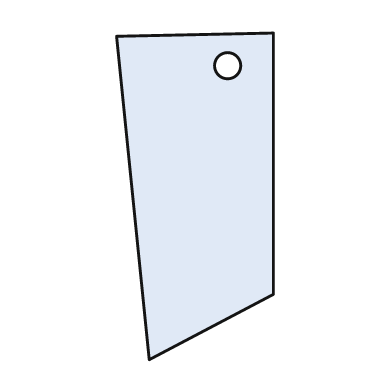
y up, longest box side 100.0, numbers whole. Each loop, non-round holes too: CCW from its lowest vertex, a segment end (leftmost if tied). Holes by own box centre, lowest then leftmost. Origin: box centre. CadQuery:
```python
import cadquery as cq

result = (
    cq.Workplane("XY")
    .moveTo(-14.0, -50.0)
    .lineTo(24.0, -30.0)
    .lineTo(24.0, 50.0)
    .lineTo(-24.0, 49.0)
    .close()
    .moveTo(10.0, 40.0)
    .circle(4.0)
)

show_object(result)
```